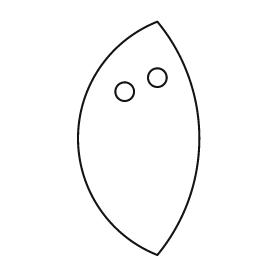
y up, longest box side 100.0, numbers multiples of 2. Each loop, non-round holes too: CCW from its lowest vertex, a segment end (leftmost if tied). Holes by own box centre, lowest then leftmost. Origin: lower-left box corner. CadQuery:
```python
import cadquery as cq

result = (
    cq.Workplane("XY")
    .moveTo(34.0, 0.0)
    .threePointArc((52.0, 50.0), (34.0, 100.0))
    .threePointArc((0.0, 50.0), (34.0, 0.0))
    .close()
    .moveTo(20.0, 70.0)
    .circle(4.0)
    .moveTo(34.0, 76.0)
    .circle(4.0)
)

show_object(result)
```